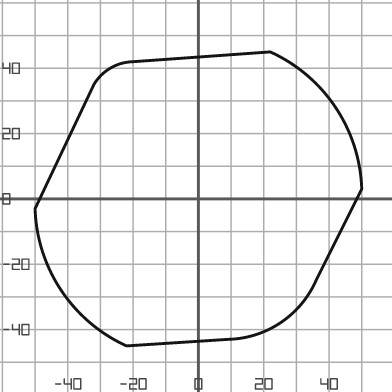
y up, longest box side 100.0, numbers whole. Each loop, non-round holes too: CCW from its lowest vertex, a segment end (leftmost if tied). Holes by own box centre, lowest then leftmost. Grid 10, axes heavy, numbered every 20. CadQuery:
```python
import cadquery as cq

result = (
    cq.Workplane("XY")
    .moveTo(-22.0, -45.0)
    .lineTo(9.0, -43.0)
    .threePointArc((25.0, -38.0), (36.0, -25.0))
    .lineTo(50.0, 3.0)
    .threePointArc((42.0, 28.0), (22.0, 45.0))
    .lineTo(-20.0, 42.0)
    .threePointArc((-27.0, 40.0), (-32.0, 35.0))
    .lineTo(-50.0, -3.0)
    .threePointArc((-42.0, -28.0), (-22.0, -45.0))
    .close()
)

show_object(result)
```